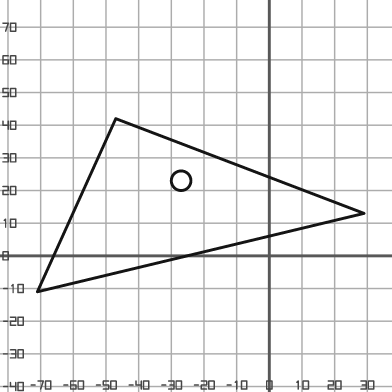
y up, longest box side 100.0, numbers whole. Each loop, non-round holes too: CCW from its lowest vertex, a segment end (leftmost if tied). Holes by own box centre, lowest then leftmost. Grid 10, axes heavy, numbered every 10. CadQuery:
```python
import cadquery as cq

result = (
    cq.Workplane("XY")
    .moveTo(-71.0, -11.0)
    .lineTo(29.0, 13.0)
    .lineTo(-47.0, 42.0)
    .close()
    .moveTo(-27.0, 23.0)
    .circle(3.0)
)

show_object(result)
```